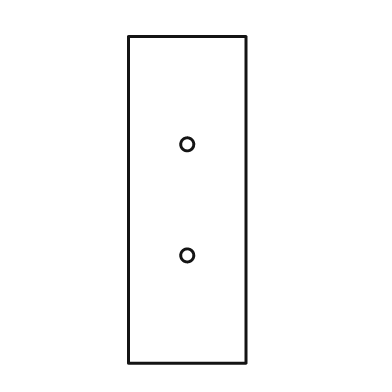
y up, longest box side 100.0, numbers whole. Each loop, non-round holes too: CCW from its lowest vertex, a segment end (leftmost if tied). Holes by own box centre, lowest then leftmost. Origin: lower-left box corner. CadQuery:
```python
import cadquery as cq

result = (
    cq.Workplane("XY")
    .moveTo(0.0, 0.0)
    .lineTo(36.0, 0.0)
    .lineTo(36.0, 100.0)
    .lineTo(0.0, 100.0)
    .close()
    .moveTo(18.0, 33.0)
    .circle(2.0)
    .moveTo(18.0, 67.0)
    .circle(2.0)
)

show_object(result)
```